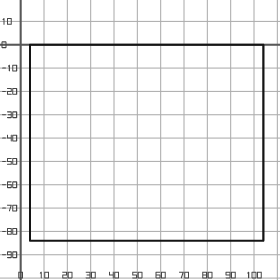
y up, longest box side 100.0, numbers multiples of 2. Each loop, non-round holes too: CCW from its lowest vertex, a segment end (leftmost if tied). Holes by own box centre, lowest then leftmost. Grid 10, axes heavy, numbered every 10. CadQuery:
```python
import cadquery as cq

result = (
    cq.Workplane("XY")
    .moveTo(4.0, -84.0)
    .lineTo(104.0, -84.0)
    .lineTo(104.0, 0.0)
    .lineTo(4.0, 0.0)
    .close()
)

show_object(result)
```